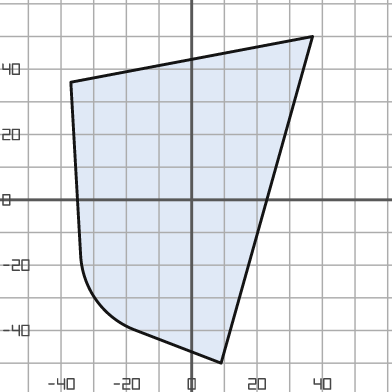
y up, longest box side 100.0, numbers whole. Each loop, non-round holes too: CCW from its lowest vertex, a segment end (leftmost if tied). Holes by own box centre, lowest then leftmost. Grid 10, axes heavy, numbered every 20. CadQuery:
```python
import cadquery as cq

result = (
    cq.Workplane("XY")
    .moveTo(9.0, -50.0)
    .lineTo(37.0, 50.0)
    .lineTo(-37.0, 36.0)
    .lineTo(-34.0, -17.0)
    .threePointArc((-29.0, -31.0), (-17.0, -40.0))
    .close()
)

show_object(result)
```